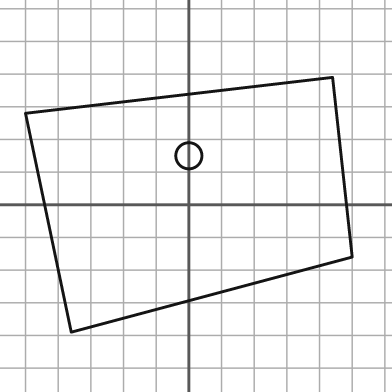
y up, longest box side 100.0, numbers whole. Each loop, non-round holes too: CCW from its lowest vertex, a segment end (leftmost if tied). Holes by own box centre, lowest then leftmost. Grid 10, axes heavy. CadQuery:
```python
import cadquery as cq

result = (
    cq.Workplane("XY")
    .moveTo(-36.0, -39.0)
    .lineTo(50.0, -16.0)
    .lineTo(44.0, 39.0)
    .lineTo(-50.0, 28.0)
    .close()
    .moveTo(0.0, 15.0)
    .circle(4.0)
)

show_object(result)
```